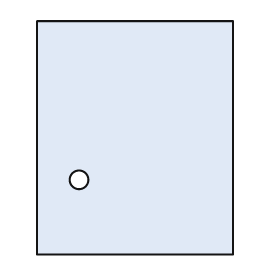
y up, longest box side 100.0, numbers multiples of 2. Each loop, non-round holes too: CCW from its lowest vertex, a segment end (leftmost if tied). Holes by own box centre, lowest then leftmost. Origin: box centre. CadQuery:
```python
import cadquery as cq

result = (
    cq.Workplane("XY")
    .moveTo(-42.0, -50.0)
    .lineTo(42.0, -50.0)
    .lineTo(42.0, 50.0)
    .lineTo(-42.0, 50.0)
    .close()
    .moveTo(-24.0, -18.0)
    .circle(4.0)
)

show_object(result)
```